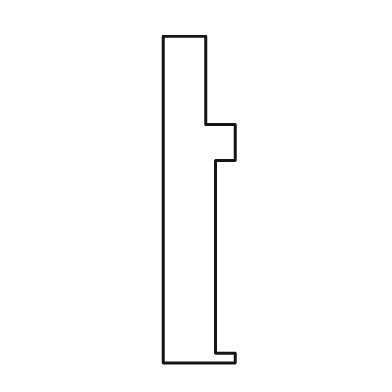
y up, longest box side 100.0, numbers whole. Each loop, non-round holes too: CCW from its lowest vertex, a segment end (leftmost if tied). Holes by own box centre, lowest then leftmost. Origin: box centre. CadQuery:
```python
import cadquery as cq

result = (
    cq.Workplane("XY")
    .moveTo(-11.0, -50.0)
    .lineTo(11.0, -50.0)
    .lineTo(11.0, -47.0)
    .lineTo(5.0, -47.0)
    .lineTo(5.0, 12.0)
    .lineTo(11.0, 12.0)
    .lineTo(11.0, 23.0)
    .lineTo(2.0, 23.0)
    .lineTo(2.0, 50.0)
    .lineTo(-11.0, 50.0)
    .close()
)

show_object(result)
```